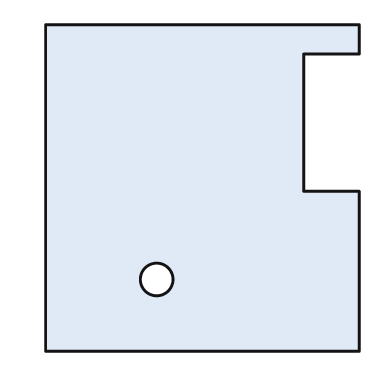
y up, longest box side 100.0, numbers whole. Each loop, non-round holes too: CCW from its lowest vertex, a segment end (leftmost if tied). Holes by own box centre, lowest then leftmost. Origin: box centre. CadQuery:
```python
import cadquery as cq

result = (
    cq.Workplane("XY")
    .moveTo(-48.0, -50.0)
    .lineTo(48.0, -50.0)
    .lineTo(48.0, -1.0)
    .lineTo(31.0, -1.0)
    .lineTo(31.0, 41.0)
    .lineTo(48.0, 41.0)
    .lineTo(48.0, 50.0)
    .lineTo(-48.0, 50.0)
    .close()
    .moveTo(-14.0, -28.0)
    .circle(5.0)
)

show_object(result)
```